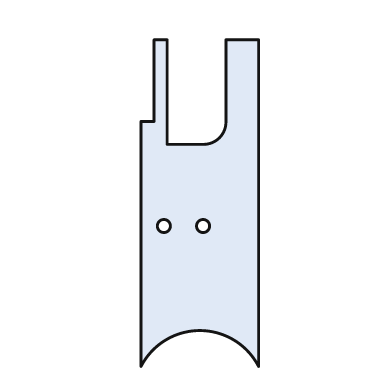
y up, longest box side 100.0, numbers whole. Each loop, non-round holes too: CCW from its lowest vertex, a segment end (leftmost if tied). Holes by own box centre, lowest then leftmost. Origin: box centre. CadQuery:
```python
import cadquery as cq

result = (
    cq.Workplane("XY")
    .moveTo(-18.0, -50.0)
    .threePointArc((0.0, -39.0), (18.0, -50.0))
    .lineTo(18.0, 50.0)
    .lineTo(8.0, 50.0)
    .lineTo(8.0, 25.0)
    .threePointArc((6.0, 20.0), (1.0, 18.0))
    .lineTo(-10.0, 18.0)
    .lineTo(-10.0, 50.0)
    .lineTo(-14.0, 50.0)
    .lineTo(-14.0, 25.0)
    .lineTo(-18.0, 25.0)
    .close()
    .moveTo(-11.0, -7.0)
    .circle(2.0)
    .moveTo(1.0, -7.0)
    .circle(2.0)
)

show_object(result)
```